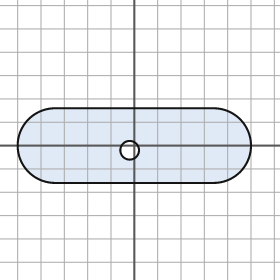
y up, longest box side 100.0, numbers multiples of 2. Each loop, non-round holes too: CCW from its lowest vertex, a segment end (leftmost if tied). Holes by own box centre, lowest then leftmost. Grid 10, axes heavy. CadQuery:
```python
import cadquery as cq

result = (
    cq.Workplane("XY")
    .moveTo(-34.0, -16.0)
    .lineTo(34.0, -16.0)
    .threePointArc((50.0, 0.0), (34.0, 16.0))
    .lineTo(-34.0, 16.0)
    .threePointArc((-50.0, 0.0), (-34.0, -16.0))
    .close()
    .moveTo(-2.0, -2.0)
    .circle(4.0)
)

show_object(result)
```